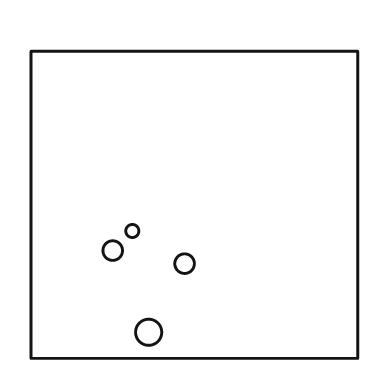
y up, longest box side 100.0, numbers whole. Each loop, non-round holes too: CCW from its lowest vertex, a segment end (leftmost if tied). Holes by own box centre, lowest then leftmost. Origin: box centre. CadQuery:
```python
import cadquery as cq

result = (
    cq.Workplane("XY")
    .moveTo(-50.0, -47.0)
    .lineTo(50.0, -47.0)
    .lineTo(50.0, 47.0)
    .lineTo(-50.0, 47.0)
    .close()
    .moveTo(-14.0, -39.0)
    .circle(4.0)
    .moveTo(-3.0, -18.0)
    .circle(3.0)
    .moveTo(-25.0, -14.0)
    .circle(3.0)
    .moveTo(-19.0, -8.0)
    .circle(2.0)
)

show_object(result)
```